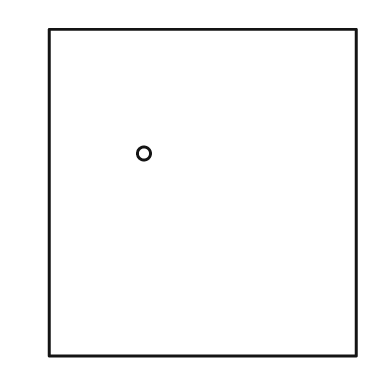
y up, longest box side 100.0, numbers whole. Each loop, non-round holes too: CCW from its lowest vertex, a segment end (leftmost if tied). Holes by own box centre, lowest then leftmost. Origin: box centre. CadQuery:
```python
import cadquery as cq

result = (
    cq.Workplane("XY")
    .moveTo(-47.0, -50.0)
    .lineTo(47.0, -50.0)
    .lineTo(47.0, 50.0)
    .lineTo(-47.0, 50.0)
    .close()
    .moveTo(-18.0, 12.0)
    .circle(2.0)
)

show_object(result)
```